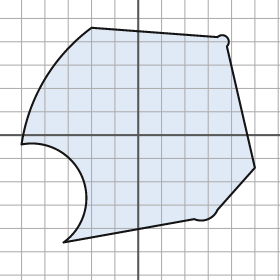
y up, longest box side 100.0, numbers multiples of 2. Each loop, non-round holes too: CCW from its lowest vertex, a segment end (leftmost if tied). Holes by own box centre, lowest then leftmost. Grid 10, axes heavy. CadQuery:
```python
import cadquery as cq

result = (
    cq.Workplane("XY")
    .moveTo(-32.0, -46.0)
    .lineTo(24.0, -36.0)
    .threePointArc((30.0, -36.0), (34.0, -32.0))
    .lineTo(50.0, -14.0)
    .lineTo(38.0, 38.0)
    .threePointArc((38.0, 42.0), (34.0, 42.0))
    .lineTo(-20.0, 46.0)
    .threePointArc((-40.0, 24.0), (-50.0, -4.0))
    .threePointArc((-24.0, -18.0), (-32.0, -46.0))
    .close()
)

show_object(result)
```